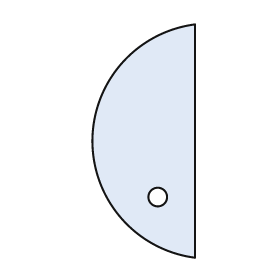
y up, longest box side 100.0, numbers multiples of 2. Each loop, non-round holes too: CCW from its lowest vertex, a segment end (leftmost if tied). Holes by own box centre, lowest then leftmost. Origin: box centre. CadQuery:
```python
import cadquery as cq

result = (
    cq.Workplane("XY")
    .moveTo(22.0, -50.0)
    .lineTo(22.0, 50.0)
    .threePointArc((-22.0, 0.0), (22.0, -50.0))
    .close()
    .moveTo(6.0, -24.0)
    .circle(4.0)
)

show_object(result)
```